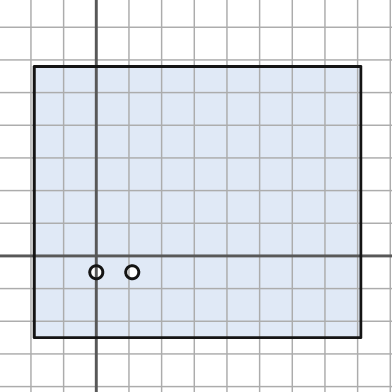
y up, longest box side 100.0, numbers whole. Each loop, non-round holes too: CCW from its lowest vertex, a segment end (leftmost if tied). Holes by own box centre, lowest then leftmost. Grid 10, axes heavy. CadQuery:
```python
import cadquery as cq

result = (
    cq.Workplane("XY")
    .moveTo(-19.0, -25.0)
    .lineTo(81.0, -25.0)
    .lineTo(81.0, 58.0)
    .lineTo(-19.0, 58.0)
    .close()
    .moveTo(0.0, -5.0)
    .circle(2.0)
    .moveTo(11.0, -5.0)
    .circle(2.0)
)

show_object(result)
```